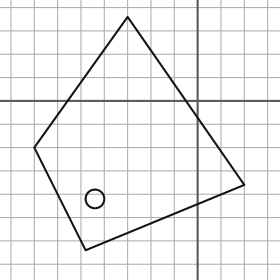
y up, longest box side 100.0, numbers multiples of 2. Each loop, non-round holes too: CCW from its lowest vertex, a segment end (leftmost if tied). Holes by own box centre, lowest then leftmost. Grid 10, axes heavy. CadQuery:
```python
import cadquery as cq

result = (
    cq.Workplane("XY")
    .moveTo(-48.0, -64.0)
    .lineTo(20.0, -36.0)
    .lineTo(-30.0, 36.0)
    .lineTo(-70.0, -20.0)
    .close()
    .moveTo(-44.0, -42.0)
    .circle(4.0)
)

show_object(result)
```